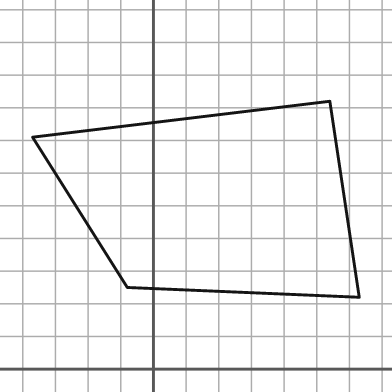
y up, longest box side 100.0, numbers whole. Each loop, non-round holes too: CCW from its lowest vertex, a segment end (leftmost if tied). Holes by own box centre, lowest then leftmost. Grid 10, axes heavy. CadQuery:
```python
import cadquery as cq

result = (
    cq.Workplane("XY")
    .moveTo(63.0, 22.0)
    .lineTo(54.0, 82.0)
    .lineTo(-37.0, 71.0)
    .lineTo(-8.0, 25.0)
    .close()
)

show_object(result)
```